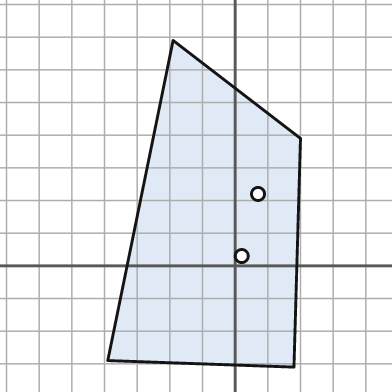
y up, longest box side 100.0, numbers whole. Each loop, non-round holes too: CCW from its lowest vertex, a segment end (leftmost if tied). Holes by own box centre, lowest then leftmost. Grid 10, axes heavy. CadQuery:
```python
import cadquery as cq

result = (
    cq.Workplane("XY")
    .moveTo(18.0, -31.0)
    .lineTo(20.0, 39.0)
    .lineTo(-19.0, 69.0)
    .lineTo(-39.0, -29.0)
    .close()
    .moveTo(2.0, 3.0)
    .circle(2.0)
    .moveTo(7.0, 22.0)
    .circle(2.0)
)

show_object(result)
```